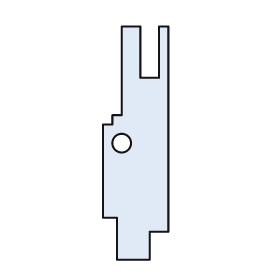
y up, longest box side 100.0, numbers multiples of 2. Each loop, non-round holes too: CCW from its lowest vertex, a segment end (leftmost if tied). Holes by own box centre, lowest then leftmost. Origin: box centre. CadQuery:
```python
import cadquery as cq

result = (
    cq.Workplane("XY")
    .moveTo(-8.0, -50.0)
    .lineTo(6.0, -50.0)
    .lineTo(6.0, -38.0)
    .lineTo(14.0, -38.0)
    .lineTo(14.0, 50.0)
    .lineTo(10.0, 50.0)
    .lineTo(10.0, 28.0)
    .lineTo(2.0, 28.0)
    .lineTo(2.0, 50.0)
    .lineTo(-6.0, 50.0)
    .lineTo(-6.0, 12.0)
    .lineTo(-10.0, 12.0)
    .lineTo(-10.0, 8.0)
    .lineTo(-14.0, 8.0)
    .lineTo(-14.0, -32.0)
    .lineTo(-8.0, -32.0)
    .close()
    .moveTo(-6.0, 0.0)
    .circle(4.0)
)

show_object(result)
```